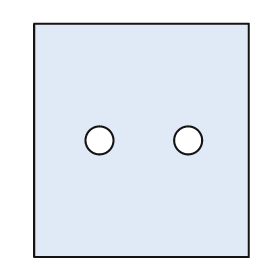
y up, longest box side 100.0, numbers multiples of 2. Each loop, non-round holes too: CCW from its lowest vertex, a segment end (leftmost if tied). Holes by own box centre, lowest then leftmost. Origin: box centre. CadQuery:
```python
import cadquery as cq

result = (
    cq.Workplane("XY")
    .moveTo(-46.0, -50.0)
    .lineTo(46.0, -50.0)
    .lineTo(46.0, 50.0)
    .lineTo(-46.0, 50.0)
    .close()
    .moveTo(-18.0, 0.0)
    .circle(6.0)
    .moveTo(20.0, 0.0)
    .circle(6.0)
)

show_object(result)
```